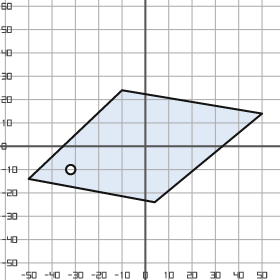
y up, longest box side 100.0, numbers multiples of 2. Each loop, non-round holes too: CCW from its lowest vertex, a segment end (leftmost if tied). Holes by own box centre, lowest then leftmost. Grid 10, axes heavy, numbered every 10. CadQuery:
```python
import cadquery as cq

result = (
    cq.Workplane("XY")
    .moveTo(4.0, -24.0)
    .lineTo(50.0, 14.0)
    .lineTo(-10.0, 24.0)
    .lineTo(-50.0, -14.0)
    .close()
    .moveTo(-32.0, -10.0)
    .circle(2.0)
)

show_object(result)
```